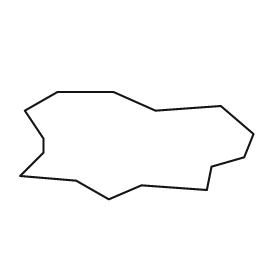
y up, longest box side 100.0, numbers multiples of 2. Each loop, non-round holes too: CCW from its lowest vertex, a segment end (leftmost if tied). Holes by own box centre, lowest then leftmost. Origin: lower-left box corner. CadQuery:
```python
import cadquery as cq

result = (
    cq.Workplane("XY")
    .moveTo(38.0, 0.0)
    .lineTo(52.0, 6.0)
    .lineTo(80.0, 4.0)
    .lineTo(82.0, 14.0)
    .lineTo(96.0, 18.0)
    .lineTo(100.0, 28.0)
    .lineTo(86.0, 40.0)
    .lineTo(58.0, 38.0)
    .lineTo(40.0, 46.0)
    .lineTo(16.0, 46.0)
    .lineTo(2.0, 38.0)
    .lineTo(10.0, 26.0)
    .lineTo(10.0, 20.0)
    .lineTo(0.0, 10.0)
    .lineTo(24.0, 8.0)
    .close()
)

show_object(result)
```